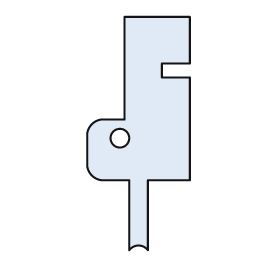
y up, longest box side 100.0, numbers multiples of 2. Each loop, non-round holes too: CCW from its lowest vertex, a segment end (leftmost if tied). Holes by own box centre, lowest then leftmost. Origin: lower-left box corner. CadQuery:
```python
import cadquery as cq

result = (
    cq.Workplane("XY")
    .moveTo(18.0, 0.0)
    .threePointArc((22.0, 2.0), (26.0, 0.0))
    .lineTo(26.0, 30.0)
    .lineTo(44.0, 30.0)
    .lineTo(44.0, 74.0)
    .lineTo(32.0, 74.0)
    .lineTo(32.0, 80.0)
    .lineTo(44.0, 80.0)
    .lineTo(44.0, 100.0)
    .lineTo(16.0, 100.0)
    .lineTo(16.0, 56.0)
    .lineTo(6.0, 56.0)
    .threePointArc((2.0, 54.0), (0.0, 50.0))
    .lineTo(0.0, 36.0)
    .threePointArc((2.0, 32.0), (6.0, 30.0))
    .lineTo(18.0, 30.0)
    .close()
    .moveTo(14.0, 48.0)
    .circle(4.0)
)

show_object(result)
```